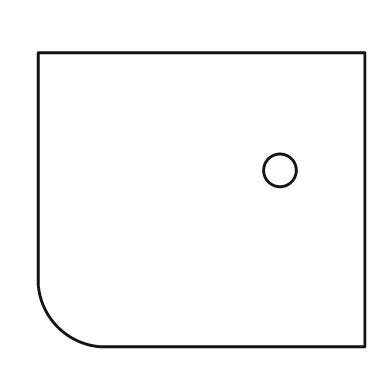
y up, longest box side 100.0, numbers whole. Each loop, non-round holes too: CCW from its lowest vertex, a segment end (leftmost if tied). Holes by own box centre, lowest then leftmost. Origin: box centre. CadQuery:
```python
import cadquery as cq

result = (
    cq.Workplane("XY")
    .moveTo(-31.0, -45.0)
    .lineTo(50.0, -45.0)
    .lineTo(50.0, 45.0)
    .lineTo(-50.0, 45.0)
    .lineTo(-50.0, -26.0)
    .threePointArc((-44.0, -39.0), (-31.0, -45.0))
    .close()
    .moveTo(24.0, 9.0)
    .circle(5.0)
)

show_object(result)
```